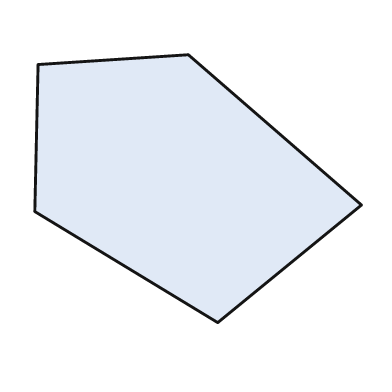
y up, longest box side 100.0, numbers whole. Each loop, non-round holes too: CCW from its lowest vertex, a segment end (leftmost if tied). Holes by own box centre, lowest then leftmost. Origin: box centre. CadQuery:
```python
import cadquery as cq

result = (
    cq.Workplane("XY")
    .moveTo(6.0, -41.0)
    .lineTo(50.0, -5.0)
    .lineTo(-3.0, 41.0)
    .lineTo(-49.0, 38.0)
    .lineTo(-50.0, -7.0)
    .close()
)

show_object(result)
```